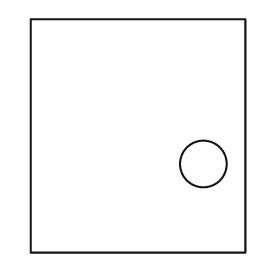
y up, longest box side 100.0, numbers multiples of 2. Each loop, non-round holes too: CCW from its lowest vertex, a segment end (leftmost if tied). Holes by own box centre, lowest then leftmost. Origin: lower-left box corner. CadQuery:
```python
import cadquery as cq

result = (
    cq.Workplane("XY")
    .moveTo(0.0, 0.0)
    .lineTo(92.0, 0.0)
    .lineTo(92.0, 100.0)
    .lineTo(0.0, 100.0)
    .close()
    .moveTo(74.0, 38.0)
    .circle(10.0)
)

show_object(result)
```